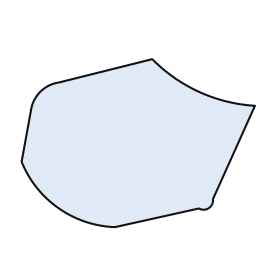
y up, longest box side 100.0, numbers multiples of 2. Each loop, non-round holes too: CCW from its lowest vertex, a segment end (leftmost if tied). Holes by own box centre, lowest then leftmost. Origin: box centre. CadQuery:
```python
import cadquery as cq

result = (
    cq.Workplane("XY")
    .moveTo(-10.0, -36.0)
    .lineTo(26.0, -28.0)
    .threePointArc((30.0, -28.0), (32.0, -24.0))
    .lineTo(50.0, 16.0)
    .threePointArc((26.0, 22.0), (6.0, 36.0))
    .lineTo(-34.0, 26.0)
    .threePointArc((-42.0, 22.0), (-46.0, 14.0))
    .lineTo(-50.0, -8.0)
    .threePointArc((-34.0, -28.0), (-10.0, -36.0))
    .close()
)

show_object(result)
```